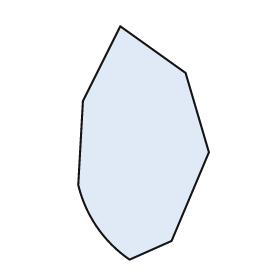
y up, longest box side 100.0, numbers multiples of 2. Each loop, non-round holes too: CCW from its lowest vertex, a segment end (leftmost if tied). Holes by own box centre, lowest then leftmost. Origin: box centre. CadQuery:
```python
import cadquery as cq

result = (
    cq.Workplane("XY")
    .moveTo(-6.0, -50.0)
    .lineTo(12.0, -42.0)
    .lineTo(28.0, -4.0)
    .lineTo(18.0, 30.0)
    .lineTo(-10.0, 50.0)
    .lineTo(-26.0, 18.0)
    .lineTo(-28.0, -18.0)
    .threePointArc((-20.0, -36.0), (-6.0, -50.0))
    .close()
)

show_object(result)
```